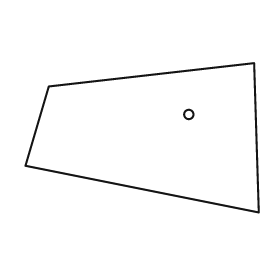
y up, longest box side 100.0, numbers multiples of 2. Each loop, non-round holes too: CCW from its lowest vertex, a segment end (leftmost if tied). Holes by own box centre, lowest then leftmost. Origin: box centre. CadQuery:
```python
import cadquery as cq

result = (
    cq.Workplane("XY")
    .moveTo(50.0, -32.0)
    .lineTo(48.0, 32.0)
    .lineTo(-40.0, 22.0)
    .lineTo(-50.0, -12.0)
    .close()
    .moveTo(20.0, 10.0)
    .circle(2.0)
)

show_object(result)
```